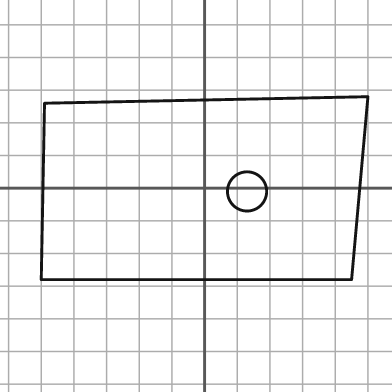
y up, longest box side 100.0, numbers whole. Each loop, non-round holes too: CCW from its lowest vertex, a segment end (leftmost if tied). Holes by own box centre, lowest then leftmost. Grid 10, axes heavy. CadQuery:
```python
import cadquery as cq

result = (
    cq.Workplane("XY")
    .moveTo(-50.0, -28.0)
    .lineTo(45.0, -28.0)
    .lineTo(50.0, 28.0)
    .lineTo(-49.0, 26.0)
    .close()
    .moveTo(13.0, -1.0)
    .circle(6.0)
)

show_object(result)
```